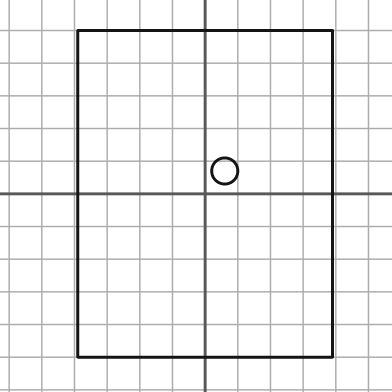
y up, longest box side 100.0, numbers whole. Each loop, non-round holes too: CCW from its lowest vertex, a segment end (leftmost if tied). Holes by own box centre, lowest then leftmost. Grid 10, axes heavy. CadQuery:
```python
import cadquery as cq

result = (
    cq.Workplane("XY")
    .moveTo(-39.0, -50.0)
    .lineTo(39.0, -50.0)
    .lineTo(39.0, 50.0)
    .lineTo(-39.0, 50.0)
    .close()
    .moveTo(6.0, 7.0)
    .circle(4.0)
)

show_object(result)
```